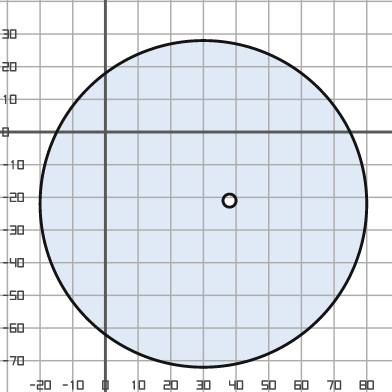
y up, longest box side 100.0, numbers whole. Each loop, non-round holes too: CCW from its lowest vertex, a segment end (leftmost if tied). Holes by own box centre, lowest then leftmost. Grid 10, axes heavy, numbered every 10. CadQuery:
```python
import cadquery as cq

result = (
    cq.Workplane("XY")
    .moveTo(30.0, -22.0)
    .circle(50.0)
    .moveTo(38.0, -21.0)
    .circle(2.0)
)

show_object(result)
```